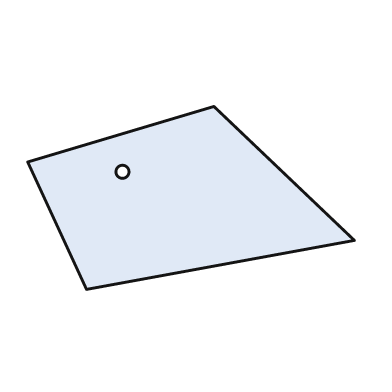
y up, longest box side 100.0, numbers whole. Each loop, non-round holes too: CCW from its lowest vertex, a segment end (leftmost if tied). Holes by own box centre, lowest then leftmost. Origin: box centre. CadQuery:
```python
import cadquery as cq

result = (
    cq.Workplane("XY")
    .moveTo(-32.0, -28.0)
    .lineTo(50.0, -13.0)
    .lineTo(7.0, 28.0)
    .lineTo(-50.0, 11.0)
    .close()
    .moveTo(-21.0, 8.0)
    .circle(2.0)
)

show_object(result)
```